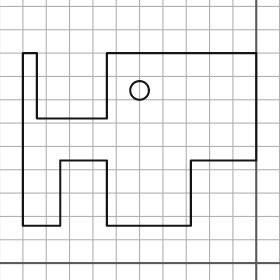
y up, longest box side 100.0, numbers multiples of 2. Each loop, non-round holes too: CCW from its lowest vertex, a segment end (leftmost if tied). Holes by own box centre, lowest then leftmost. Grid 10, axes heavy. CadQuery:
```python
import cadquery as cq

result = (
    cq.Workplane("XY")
    .moveTo(-100.0, 16.0)
    .lineTo(-84.0, 16.0)
    .lineTo(-84.0, 44.0)
    .lineTo(-64.0, 44.0)
    .lineTo(-64.0, 16.0)
    .lineTo(-28.0, 16.0)
    .lineTo(-28.0, 44.0)
    .lineTo(0.0, 44.0)
    .lineTo(0.0, 90.0)
    .lineTo(-64.0, 90.0)
    .lineTo(-64.0, 62.0)
    .lineTo(-94.0, 62.0)
    .lineTo(-94.0, 90.0)
    .lineTo(-100.0, 90.0)
    .close()
    .moveTo(-50.0, 74.0)
    .circle(4.0)
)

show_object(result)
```